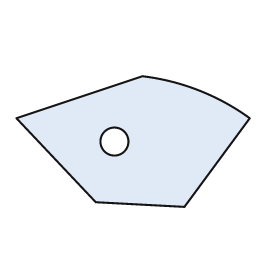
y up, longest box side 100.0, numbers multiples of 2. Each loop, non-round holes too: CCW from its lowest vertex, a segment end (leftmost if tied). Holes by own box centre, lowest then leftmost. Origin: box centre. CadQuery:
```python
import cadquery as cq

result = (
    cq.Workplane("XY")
    .moveTo(22.0, -28.0)
    .lineTo(50.0, 10.0)
    .threePointArc((28.0, 22.0), (4.0, 28.0))
    .lineTo(-50.0, 10.0)
    .lineTo(-16.0, -26.0)
    .close()
    .moveTo(-8.0, 0.0)
    .circle(6.0)
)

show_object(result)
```